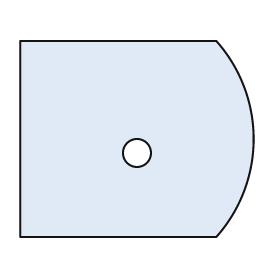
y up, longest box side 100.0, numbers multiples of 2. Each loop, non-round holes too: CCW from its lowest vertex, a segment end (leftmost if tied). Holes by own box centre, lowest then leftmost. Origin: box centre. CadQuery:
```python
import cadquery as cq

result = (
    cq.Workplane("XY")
    .moveTo(-50.0, -42.0)
    .lineTo(34.0, -42.0)
    .threePointArc((50.0, 0.0), (34.0, 42.0))
    .lineTo(-50.0, 42.0)
    .close()
    .moveTo(0.0, -6.0)
    .circle(6.0)
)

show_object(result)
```